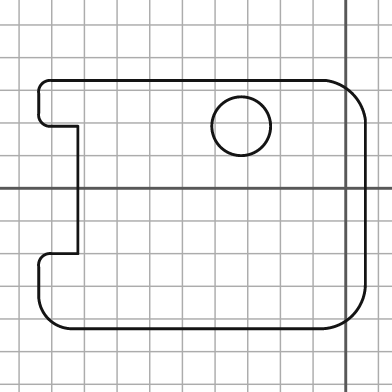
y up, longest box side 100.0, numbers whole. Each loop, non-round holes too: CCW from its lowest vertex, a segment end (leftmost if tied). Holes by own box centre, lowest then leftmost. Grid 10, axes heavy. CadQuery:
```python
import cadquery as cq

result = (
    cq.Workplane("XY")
    .moveTo(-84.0, -43.0)
    .lineTo(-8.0, -43.0)
    .threePointArc((2.0, -39.0), (6.0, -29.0))
    .lineTo(6.0, 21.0)
    .threePointArc((2.0, 29.0), (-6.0, 33.0))
    .lineTo(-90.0, 33.0)
    .threePointArc((-93.0, 32.0), (-94.0, 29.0))
    .lineTo(-94.0, 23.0)
    .threePointArc((-93.0, 20.0), (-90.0, 19.0))
    .lineTo(-82.0, 19.0)
    .lineTo(-82.0, -20.0)
    .lineTo(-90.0, -20.0)
    .threePointArc((-93.0, -21.0), (-94.0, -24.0))
    .lineTo(-94.0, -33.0)
    .threePointArc((-91.0, -40.0), (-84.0, -43.0))
    .close()
    .moveTo(-32.0, 19.0)
    .circle(9.0)
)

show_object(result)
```